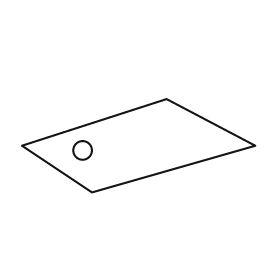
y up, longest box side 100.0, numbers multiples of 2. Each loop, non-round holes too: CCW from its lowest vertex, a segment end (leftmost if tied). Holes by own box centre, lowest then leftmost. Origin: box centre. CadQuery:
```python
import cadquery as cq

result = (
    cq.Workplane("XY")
    .moveTo(-20.0, -20.0)
    .lineTo(50.0, 0.0)
    .lineTo(12.0, 20.0)
    .lineTo(-50.0, 0.0)
    .close()
    .moveTo(-24.0, -2.0)
    .circle(4.0)
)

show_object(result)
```